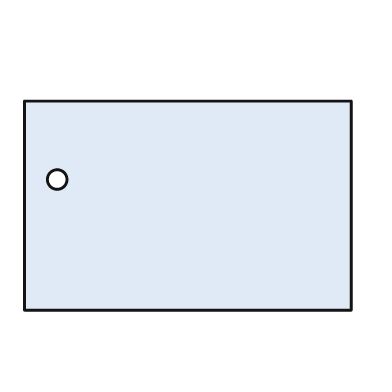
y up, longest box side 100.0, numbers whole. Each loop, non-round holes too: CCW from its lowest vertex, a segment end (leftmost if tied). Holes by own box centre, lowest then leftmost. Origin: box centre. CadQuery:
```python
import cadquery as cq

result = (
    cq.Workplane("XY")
    .moveTo(-50.0, -32.0)
    .lineTo(50.0, -32.0)
    .lineTo(50.0, 32.0)
    .lineTo(-50.0, 32.0)
    .close()
    .moveTo(-40.0, 8.0)
    .circle(3.0)
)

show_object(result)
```